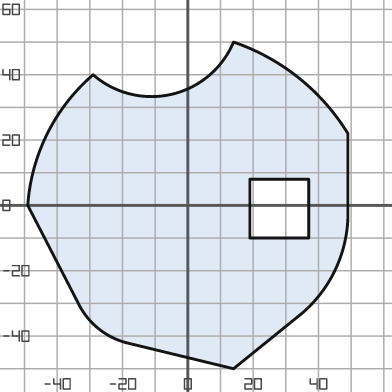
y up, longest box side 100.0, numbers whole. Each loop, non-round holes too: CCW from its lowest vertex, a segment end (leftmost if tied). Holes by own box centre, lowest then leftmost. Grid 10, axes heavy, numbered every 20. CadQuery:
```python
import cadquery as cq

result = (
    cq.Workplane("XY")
    .moveTo(14.0, -50.0)
    .lineTo(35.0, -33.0)
    .threePointArc((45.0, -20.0), (49.0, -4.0))
    .lineTo(49.0, 22.0)
    .threePointArc((34.0, 39.0), (14.0, 50.0))
    .threePointArc((-5.0, 34.0), (-29.0, 40.0))
    .threePointArc((-43.0, 22.0), (-49.0, 0.0))
    .lineTo(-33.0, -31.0)
    .threePointArc((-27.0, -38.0), (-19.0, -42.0))
    .close()
    .moveTo(19.0, -10.0)
    .lineTo(37.0, -10.0)
    .lineTo(37.0, 8.0)
    .lineTo(19.0, 8.0)
    .close()
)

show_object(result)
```